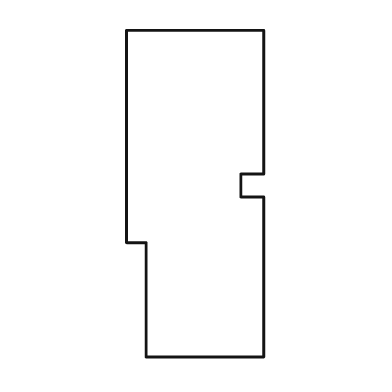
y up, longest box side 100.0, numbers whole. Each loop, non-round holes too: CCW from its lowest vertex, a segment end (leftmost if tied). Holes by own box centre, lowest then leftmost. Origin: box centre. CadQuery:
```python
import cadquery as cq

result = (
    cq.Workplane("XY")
    .moveTo(-15.0, -50.0)
    .lineTo(21.0, -50.0)
    .lineTo(21.0, -1.0)
    .lineTo(14.0, -1.0)
    .lineTo(14.0, 6.0)
    .lineTo(21.0, 6.0)
    .lineTo(21.0, 50.0)
    .lineTo(-21.0, 50.0)
    .lineTo(-21.0, -15.0)
    .lineTo(-15.0, -15.0)
    .close()
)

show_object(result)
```